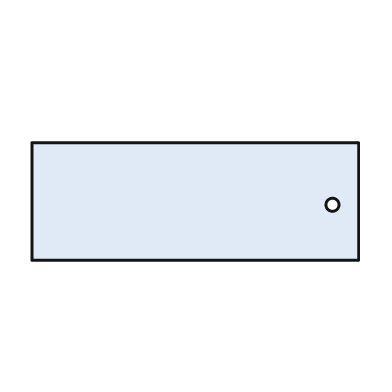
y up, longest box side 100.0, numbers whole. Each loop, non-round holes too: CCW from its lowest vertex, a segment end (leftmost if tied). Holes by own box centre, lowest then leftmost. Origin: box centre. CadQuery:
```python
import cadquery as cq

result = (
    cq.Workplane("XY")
    .moveTo(-50.0, -18.0)
    .lineTo(50.0, -18.0)
    .lineTo(50.0, 18.0)
    .lineTo(-50.0, 18.0)
    .close()
    .moveTo(42.0, -1.0)
    .circle(2.0)
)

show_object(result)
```